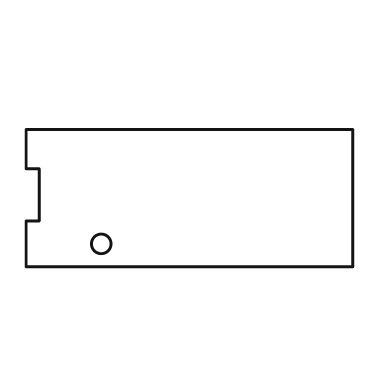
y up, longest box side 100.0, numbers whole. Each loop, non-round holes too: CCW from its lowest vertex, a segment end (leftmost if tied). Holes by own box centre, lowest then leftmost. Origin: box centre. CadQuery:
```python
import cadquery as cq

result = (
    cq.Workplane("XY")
    .moveTo(-50.0, -21.0)
    .lineTo(50.0, -21.0)
    .lineTo(50.0, 21.0)
    .lineTo(-50.0, 21.0)
    .lineTo(-50.0, 9.0)
    .lineTo(-46.0, 9.0)
    .lineTo(-46.0, -7.0)
    .lineTo(-50.0, -7.0)
    .close()
    .moveTo(-27.0, -14.0)
    .circle(3.0)
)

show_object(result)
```